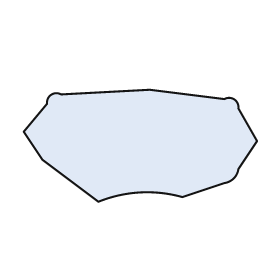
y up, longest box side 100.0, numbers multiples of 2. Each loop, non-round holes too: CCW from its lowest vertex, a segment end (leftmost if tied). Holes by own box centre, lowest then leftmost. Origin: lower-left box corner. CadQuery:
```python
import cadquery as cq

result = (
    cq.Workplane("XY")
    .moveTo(32.0, 0.0)
    .threePointArc((50.0, 4.0), (68.0, 2.0))
    .lineTo(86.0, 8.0)
    .threePointArc((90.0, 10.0), (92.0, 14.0))
    .lineTo(100.0, 26.0)
    .lineTo(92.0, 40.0)
    .threePointArc((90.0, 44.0), (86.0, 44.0))
    .lineTo(54.0, 48.0)
    .lineTo(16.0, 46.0)
    .threePointArc((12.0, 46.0), (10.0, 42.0))
    .lineTo(0.0, 30.0)
    .lineTo(8.0, 18.0)
    .close()
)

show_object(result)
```